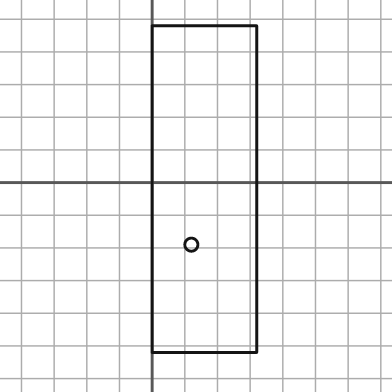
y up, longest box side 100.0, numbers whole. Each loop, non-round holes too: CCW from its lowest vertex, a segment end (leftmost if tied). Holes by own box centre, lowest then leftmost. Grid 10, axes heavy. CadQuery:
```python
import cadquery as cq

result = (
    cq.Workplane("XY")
    .moveTo(0.0, -52.0)
    .lineTo(32.0, -52.0)
    .lineTo(32.0, 48.0)
    .lineTo(0.0, 48.0)
    .close()
    .moveTo(12.0, -19.0)
    .circle(2.0)
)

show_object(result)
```